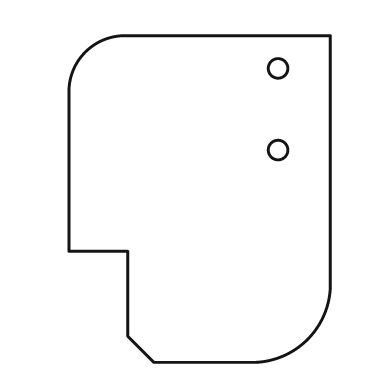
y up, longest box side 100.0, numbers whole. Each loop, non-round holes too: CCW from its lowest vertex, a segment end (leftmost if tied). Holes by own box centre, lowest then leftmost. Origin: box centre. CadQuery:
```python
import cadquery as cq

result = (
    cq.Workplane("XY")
    .moveTo(-14.0, -50.0)
    .lineTo(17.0, -50.0)
    .threePointArc((33.0, -43.0), (40.0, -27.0))
    .lineTo(40.0, 50.0)
    .lineTo(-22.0, 50.0)
    .threePointArc((-35.0, 45.0), (-40.0, 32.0))
    .lineTo(-40.0, -16.0)
    .lineTo(-22.0, -16.0)
    .lineTo(-22.0, -42.0)
    .close()
    .moveTo(24.0, 15.0)
    .circle(3.0)
    .moveTo(24.0, 40.0)
    .circle(3.0)
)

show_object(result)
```